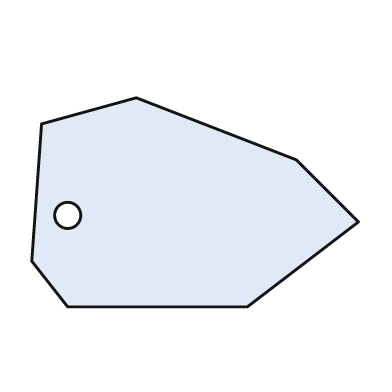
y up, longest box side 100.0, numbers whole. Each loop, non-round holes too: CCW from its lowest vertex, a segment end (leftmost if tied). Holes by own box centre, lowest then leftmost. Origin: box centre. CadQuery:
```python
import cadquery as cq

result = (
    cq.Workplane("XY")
    .moveTo(-39.0, -32.0)
    .lineTo(16.0, -32.0)
    .lineTo(50.0, -6.0)
    .lineTo(31.0, 13.0)
    .lineTo(-18.0, 32.0)
    .lineTo(-47.0, 24.0)
    .lineTo(-50.0, -18.0)
    .close()
    .moveTo(-39.0, -4.0)
    .circle(4.0)
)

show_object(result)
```